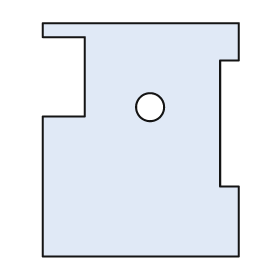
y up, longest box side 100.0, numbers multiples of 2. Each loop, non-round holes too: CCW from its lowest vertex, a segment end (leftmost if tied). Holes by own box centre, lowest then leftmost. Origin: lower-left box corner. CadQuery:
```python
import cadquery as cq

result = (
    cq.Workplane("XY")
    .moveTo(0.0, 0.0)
    .lineTo(84.0, 0.0)
    .lineTo(84.0, 30.0)
    .lineTo(76.0, 30.0)
    .lineTo(76.0, 84.0)
    .lineTo(84.0, 84.0)
    .lineTo(84.0, 100.0)
    .lineTo(0.0, 100.0)
    .lineTo(0.0, 94.0)
    .lineTo(18.0, 94.0)
    .lineTo(18.0, 60.0)
    .lineTo(0.0, 60.0)
    .close()
    .moveTo(46.0, 64.0)
    .circle(6.0)
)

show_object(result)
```